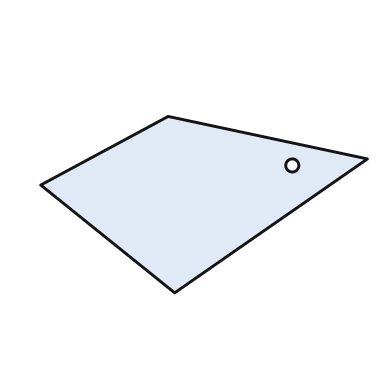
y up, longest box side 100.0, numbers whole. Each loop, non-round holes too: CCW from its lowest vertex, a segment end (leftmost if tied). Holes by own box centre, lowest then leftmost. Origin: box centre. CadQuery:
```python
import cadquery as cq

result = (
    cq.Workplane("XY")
    .moveTo(-9.0, -27.0)
    .lineTo(50.0, 14.0)
    .lineTo(-11.0, 27.0)
    .lineTo(-50.0, 6.0)
    .close()
    .moveTo(27.0, 12.0)
    .circle(2.0)
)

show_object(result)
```